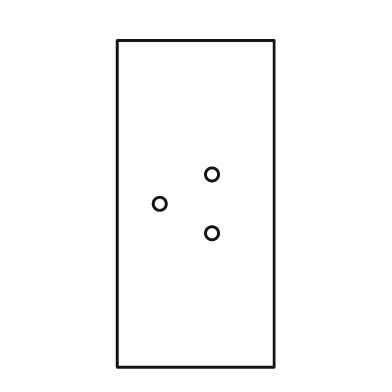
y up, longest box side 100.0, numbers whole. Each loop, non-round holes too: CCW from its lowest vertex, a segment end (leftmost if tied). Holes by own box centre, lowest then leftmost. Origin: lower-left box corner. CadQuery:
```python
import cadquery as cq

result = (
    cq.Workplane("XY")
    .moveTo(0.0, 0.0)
    .lineTo(48.0, 0.0)
    .lineTo(48.0, 100.0)
    .lineTo(0.0, 100.0)
    .close()
    .moveTo(29.0, 41.0)
    .circle(2.0)
    .moveTo(13.0, 50.0)
    .circle(2.0)
    .moveTo(29.0, 59.0)
    .circle(2.0)
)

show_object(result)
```